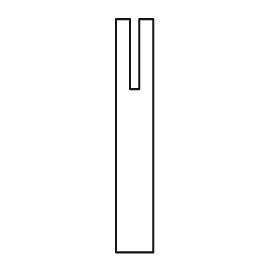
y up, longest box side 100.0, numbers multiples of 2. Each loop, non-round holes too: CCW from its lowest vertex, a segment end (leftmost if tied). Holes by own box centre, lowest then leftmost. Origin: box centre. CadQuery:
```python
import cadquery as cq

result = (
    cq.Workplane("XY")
    .moveTo(-8.0, -50.0)
    .lineTo(8.0, -50.0)
    .lineTo(8.0, 50.0)
    .lineTo(2.0, 50.0)
    .lineTo(2.0, 20.0)
    .lineTo(-2.0, 20.0)
    .lineTo(-2.0, 50.0)
    .lineTo(-8.0, 50.0)
    .close()
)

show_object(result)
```